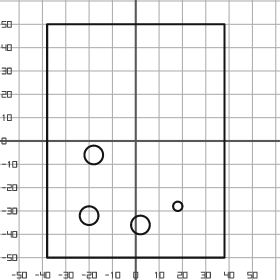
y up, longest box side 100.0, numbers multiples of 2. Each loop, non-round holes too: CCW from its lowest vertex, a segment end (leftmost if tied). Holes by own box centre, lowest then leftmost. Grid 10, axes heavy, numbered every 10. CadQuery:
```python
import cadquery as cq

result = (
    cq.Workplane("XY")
    .moveTo(-38.0, -50.0)
    .lineTo(38.0, -50.0)
    .lineTo(38.0, 50.0)
    .lineTo(-38.0, 50.0)
    .close()
    .moveTo(2.0, -36.0)
    .circle(4.0)
    .moveTo(-20.0, -32.0)
    .circle(4.0)
    .moveTo(18.0, -28.0)
    .circle(2.0)
    .moveTo(-18.0, -6.0)
    .circle(4.0)
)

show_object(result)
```